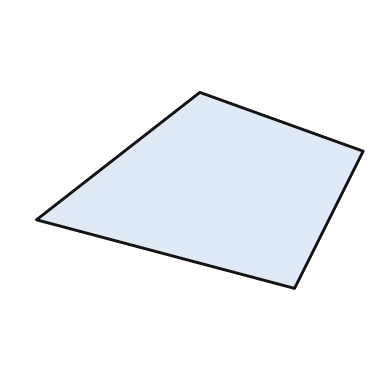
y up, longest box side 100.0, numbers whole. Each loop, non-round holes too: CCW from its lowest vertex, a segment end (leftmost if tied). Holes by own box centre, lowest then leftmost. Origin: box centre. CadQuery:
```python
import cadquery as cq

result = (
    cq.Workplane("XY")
    .moveTo(29.0, -30.0)
    .lineTo(50.0, 12.0)
    .lineTo(0.0, 30.0)
    .lineTo(-50.0, -9.0)
    .close()
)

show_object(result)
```